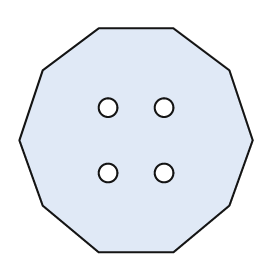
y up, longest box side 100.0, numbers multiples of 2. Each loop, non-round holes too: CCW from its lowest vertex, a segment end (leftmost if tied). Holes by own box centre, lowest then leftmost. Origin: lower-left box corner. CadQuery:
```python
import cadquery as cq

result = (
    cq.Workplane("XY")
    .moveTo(34.0, 0.0)
    .lineTo(66.0, 0.0)
    .lineTo(90.0, 20.0)
    .lineTo(100.0, 48.0)
    .lineTo(90.0, 78.0)
    .lineTo(66.0, 96.0)
    .lineTo(34.0, 96.0)
    .lineTo(10.0, 78.0)
    .lineTo(0.0, 48.0)
    .lineTo(10.0, 20.0)
    .close()
    .moveTo(38.0, 34.0)
    .circle(4.0)
    .moveTo(62.0, 34.0)
    .circle(4.0)
    .moveTo(38.0, 62.0)
    .circle(4.0)
    .moveTo(62.0, 62.0)
    .circle(4.0)
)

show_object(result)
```